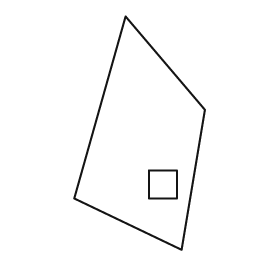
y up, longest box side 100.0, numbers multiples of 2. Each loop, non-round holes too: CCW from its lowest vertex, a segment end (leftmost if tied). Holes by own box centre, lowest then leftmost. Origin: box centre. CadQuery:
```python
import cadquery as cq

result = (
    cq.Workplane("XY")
    .moveTo(18.0, -50.0)
    .lineTo(28.0, 10.0)
    .lineTo(-6.0, 50.0)
    .lineTo(-28.0, -28.0)
    .close()
    .moveTo(4.0, -28.0)
    .lineTo(16.0, -28.0)
    .lineTo(16.0, -16.0)
    .lineTo(4.0, -16.0)
    .close()
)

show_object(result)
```